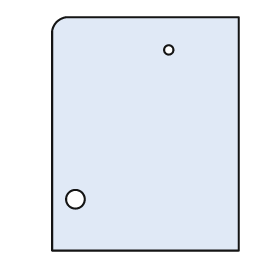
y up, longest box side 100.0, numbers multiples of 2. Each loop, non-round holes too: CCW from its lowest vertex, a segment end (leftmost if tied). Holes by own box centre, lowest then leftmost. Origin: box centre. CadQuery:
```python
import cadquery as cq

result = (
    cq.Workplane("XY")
    .moveTo(-40.0, -50.0)
    .lineTo(40.0, -50.0)
    .lineTo(40.0, 50.0)
    .lineTo(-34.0, 50.0)
    .threePointArc((-38.0, 48.0), (-40.0, 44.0))
    .close()
    .moveTo(-30.0, -28.0)
    .circle(4.0)
    .moveTo(10.0, 36.0)
    .circle(2.0)
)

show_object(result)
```